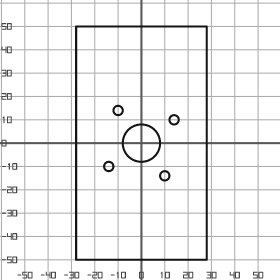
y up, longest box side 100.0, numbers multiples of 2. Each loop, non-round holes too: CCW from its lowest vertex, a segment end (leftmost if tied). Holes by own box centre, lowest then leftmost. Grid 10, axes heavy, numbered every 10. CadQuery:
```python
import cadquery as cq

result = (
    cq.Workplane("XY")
    .moveTo(-28.0, -50.0)
    .lineTo(28.0, -50.0)
    .lineTo(28.0, 50.0)
    .lineTo(-28.0, 50.0)
    .close()
    .moveTo(10.0, -14.0)
    .circle(2.0)
    .moveTo(-14.0, -10.0)
    .circle(2.0)
    .moveTo(0.0, 0.0)
    .circle(8.0)
    .moveTo(14.0, 10.0)
    .circle(2.0)
    .moveTo(-10.0, 14.0)
    .circle(2.0)
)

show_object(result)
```